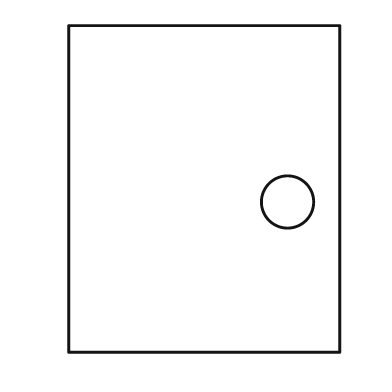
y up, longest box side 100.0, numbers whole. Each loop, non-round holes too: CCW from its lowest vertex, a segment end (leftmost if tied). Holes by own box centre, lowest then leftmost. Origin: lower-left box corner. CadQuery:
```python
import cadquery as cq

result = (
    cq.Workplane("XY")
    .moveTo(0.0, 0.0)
    .lineTo(83.0, 0.0)
    .lineTo(83.0, 100.0)
    .lineTo(0.0, 100.0)
    .close()
    .moveTo(67.0, 46.0)
    .circle(8.0)
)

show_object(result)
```